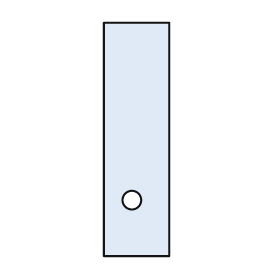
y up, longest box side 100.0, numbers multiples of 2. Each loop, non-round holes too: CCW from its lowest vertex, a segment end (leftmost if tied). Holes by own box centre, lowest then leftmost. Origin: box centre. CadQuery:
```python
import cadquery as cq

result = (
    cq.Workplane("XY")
    .moveTo(-14.0, -50.0)
    .lineTo(14.0, -50.0)
    .lineTo(14.0, 50.0)
    .lineTo(-14.0, 50.0)
    .close()
    .moveTo(-2.0, -26.0)
    .circle(4.0)
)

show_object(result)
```